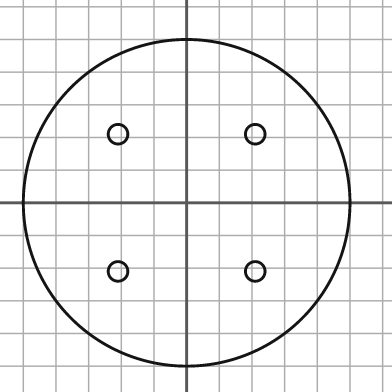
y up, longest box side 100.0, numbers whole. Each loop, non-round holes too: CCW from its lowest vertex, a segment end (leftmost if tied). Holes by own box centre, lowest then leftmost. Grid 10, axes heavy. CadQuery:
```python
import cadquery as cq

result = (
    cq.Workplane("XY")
    .moveTo(0.0, 0.0)
    .circle(50.0)
    .moveTo(-21.0, -21.0)
    .circle(3.0)
    .moveTo(21.0, -21.0)
    .circle(3.0)
    .moveTo(-21.0, 21.0)
    .circle(3.0)
    .moveTo(21.0, 21.0)
    .circle(3.0)
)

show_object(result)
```